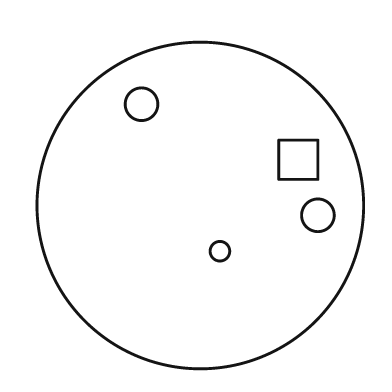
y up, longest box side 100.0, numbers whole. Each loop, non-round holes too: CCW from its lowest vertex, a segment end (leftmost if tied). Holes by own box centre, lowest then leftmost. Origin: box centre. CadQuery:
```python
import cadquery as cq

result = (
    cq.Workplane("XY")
    .moveTo(0.0, 0.0)
    .circle(50.0)
    .moveTo(6.0, -14.0)
    .circle(3.0)
    .moveTo(36.0, -3.0)
    .circle(5.0)
    .moveTo(24.0, 8.0)
    .lineTo(36.0, 8.0)
    .lineTo(36.0, 20.0)
    .lineTo(24.0, 20.0)
    .close()
    .moveTo(-18.0, 31.0)
    .circle(5.0)
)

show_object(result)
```